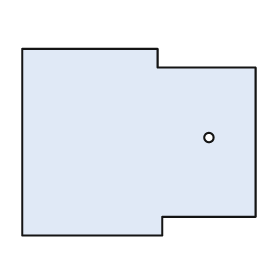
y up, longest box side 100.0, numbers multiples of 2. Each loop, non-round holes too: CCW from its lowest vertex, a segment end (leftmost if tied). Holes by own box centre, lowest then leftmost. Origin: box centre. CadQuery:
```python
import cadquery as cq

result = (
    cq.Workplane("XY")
    .moveTo(-50.0, -40.0)
    .lineTo(10.0, -40.0)
    .lineTo(10.0, -32.0)
    .lineTo(50.0, -32.0)
    .lineTo(50.0, 32.0)
    .lineTo(8.0, 32.0)
    .lineTo(8.0, 40.0)
    .lineTo(-50.0, 40.0)
    .close()
    .moveTo(30.0, 2.0)
    .circle(2.0)
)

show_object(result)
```